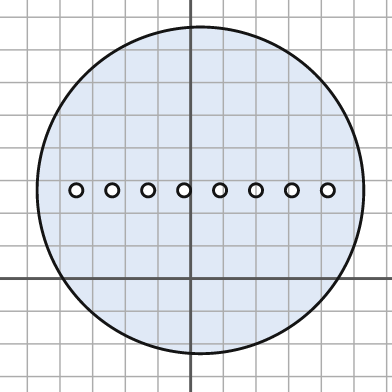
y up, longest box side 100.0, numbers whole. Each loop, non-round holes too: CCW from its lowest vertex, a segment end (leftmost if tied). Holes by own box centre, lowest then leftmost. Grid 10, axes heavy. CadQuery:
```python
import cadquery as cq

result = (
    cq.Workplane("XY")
    .moveTo(3.0, 27.0)
    .circle(50.0)
    .moveTo(-35.0, 27.0)
    .circle(2.0)
    .moveTo(-24.0, 27.0)
    .circle(2.0)
    .moveTo(-13.0, 27.0)
    .circle(2.0)
    .moveTo(-2.0, 27.0)
    .circle(2.0)
    .moveTo(9.0, 27.0)
    .circle(2.0)
    .moveTo(20.0, 27.0)
    .circle(2.0)
    .moveTo(31.0, 27.0)
    .circle(2.0)
    .moveTo(42.0, 27.0)
    .circle(2.0)
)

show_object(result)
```